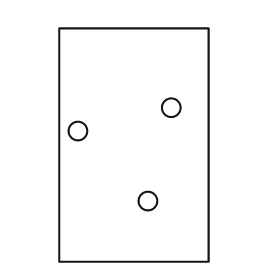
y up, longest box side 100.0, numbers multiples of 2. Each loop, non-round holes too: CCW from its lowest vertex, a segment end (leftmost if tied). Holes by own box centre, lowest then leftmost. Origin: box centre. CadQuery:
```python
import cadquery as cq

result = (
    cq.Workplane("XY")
    .moveTo(-32.0, -50.0)
    .lineTo(32.0, -50.0)
    .lineTo(32.0, 50.0)
    .lineTo(-32.0, 50.0)
    .close()
    .moveTo(6.0, -24.0)
    .circle(4.0)
    .moveTo(-24.0, 6.0)
    .circle(4.0)
    .moveTo(16.0, 16.0)
    .circle(4.0)
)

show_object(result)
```